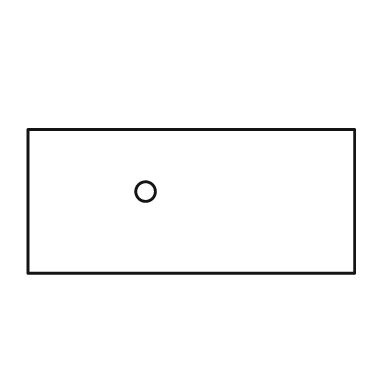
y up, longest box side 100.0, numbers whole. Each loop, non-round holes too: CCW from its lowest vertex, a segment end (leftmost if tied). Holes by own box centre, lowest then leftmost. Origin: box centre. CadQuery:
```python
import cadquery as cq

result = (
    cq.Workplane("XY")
    .moveTo(-50.0, -22.0)
    .lineTo(50.0, -22.0)
    .lineTo(50.0, 22.0)
    .lineTo(-50.0, 22.0)
    .close()
    .moveTo(-14.0, 3.0)
    .circle(3.0)
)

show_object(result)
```